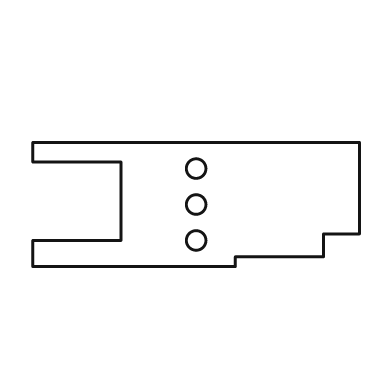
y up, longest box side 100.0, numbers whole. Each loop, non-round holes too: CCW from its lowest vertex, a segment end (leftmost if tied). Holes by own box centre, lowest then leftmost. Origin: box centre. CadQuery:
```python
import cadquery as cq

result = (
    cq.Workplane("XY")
    .moveTo(-50.0, -19.0)
    .lineTo(12.0, -19.0)
    .lineTo(12.0, -16.0)
    .lineTo(39.0, -16.0)
    .lineTo(39.0, -9.0)
    .lineTo(50.0, -9.0)
    .lineTo(50.0, 19.0)
    .lineTo(-50.0, 19.0)
    .lineTo(-50.0, 13.0)
    .lineTo(-23.0, 13.0)
    .lineTo(-23.0, -11.0)
    .lineTo(-50.0, -11.0)
    .close()
    .moveTo(0.0, -11.0)
    .circle(3.0)
    .moveTo(0.0, 0.0)
    .circle(3.0)
    .moveTo(0.0, 11.0)
    .circle(3.0)
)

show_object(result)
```